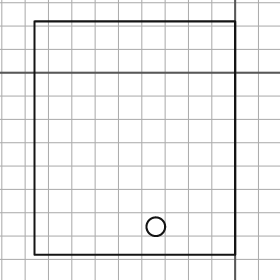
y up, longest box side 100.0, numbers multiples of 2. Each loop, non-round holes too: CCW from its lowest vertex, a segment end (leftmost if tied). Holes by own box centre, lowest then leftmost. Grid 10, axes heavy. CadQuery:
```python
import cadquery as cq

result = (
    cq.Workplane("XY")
    .moveTo(-86.0, -78.0)
    .lineTo(0.0, -78.0)
    .lineTo(0.0, 22.0)
    .lineTo(-86.0, 22.0)
    .close()
    .moveTo(-34.0, -66.0)
    .circle(4.0)
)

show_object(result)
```